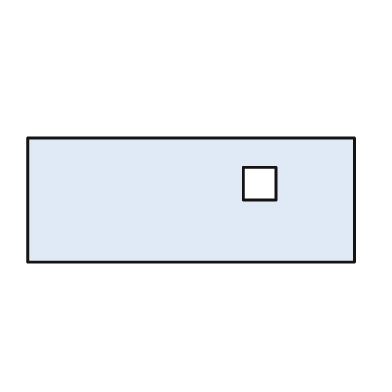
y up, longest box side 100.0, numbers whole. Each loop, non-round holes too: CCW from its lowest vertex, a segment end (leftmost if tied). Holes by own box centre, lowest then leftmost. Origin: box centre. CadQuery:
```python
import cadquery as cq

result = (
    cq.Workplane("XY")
    .moveTo(-50.0, -19.0)
    .lineTo(50.0, -19.0)
    .lineTo(50.0, 19.0)
    .lineTo(-50.0, 19.0)
    .close()
    .moveTo(16.0, 0.0)
    .lineTo(26.0, 0.0)
    .lineTo(26.0, 10.0)
    .lineTo(16.0, 10.0)
    .close()
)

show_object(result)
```